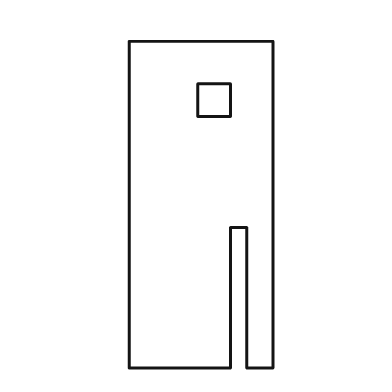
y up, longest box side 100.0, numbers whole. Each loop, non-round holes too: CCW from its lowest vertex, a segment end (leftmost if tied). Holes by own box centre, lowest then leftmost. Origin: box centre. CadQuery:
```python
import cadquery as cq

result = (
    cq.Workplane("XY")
    .moveTo(-22.0, -50.0)
    .lineTo(9.0, -50.0)
    .lineTo(9.0, -7.0)
    .lineTo(14.0, -7.0)
    .lineTo(14.0, -50.0)
    .lineTo(22.0, -50.0)
    .lineTo(22.0, 50.0)
    .lineTo(-22.0, 50.0)
    .close()
    .moveTo(-1.0, 27.0)
    .lineTo(9.0, 27.0)
    .lineTo(9.0, 37.0)
    .lineTo(-1.0, 37.0)
    .close()
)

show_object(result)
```